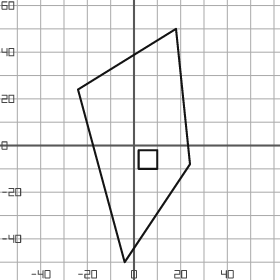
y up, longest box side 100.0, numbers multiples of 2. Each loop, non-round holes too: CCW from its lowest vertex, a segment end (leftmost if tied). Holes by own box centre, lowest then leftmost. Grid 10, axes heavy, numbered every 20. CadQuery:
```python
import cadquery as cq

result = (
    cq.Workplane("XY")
    .moveTo(-4.0, -50.0)
    .lineTo(24.0, -8.0)
    .lineTo(18.0, 50.0)
    .lineTo(-24.0, 24.0)
    .close()
    .moveTo(2.0, -10.0)
    .lineTo(10.0, -10.0)
    .lineTo(10.0, -2.0)
    .lineTo(2.0, -2.0)
    .close()
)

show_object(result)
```